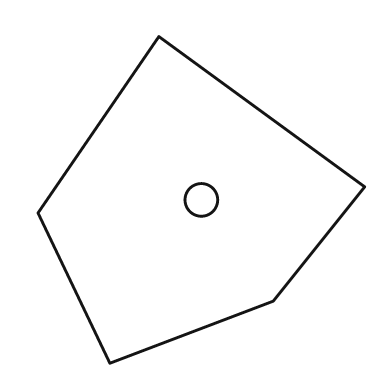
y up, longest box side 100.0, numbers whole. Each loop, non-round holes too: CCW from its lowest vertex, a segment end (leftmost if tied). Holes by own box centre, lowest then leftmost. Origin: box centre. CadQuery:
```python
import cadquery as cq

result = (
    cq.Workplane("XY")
    .moveTo(-28.0, -50.0)
    .lineTo(22.0, -31.0)
    .lineTo(50.0, 4.0)
    .lineTo(-13.0, 50.0)
    .lineTo(-50.0, -4.0)
    .close()
    .moveTo(0.0, 0.0)
    .circle(5.0)
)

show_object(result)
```